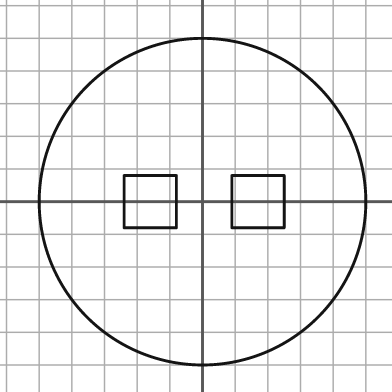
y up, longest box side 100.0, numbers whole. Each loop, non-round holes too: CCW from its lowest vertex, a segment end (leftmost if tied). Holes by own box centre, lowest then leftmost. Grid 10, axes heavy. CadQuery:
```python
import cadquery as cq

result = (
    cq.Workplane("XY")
    .moveTo(0.0, 0.0)
    .circle(50.0)
    .moveTo(-24.0, -8.0)
    .lineTo(-8.0, -8.0)
    .lineTo(-8.0, 8.0)
    .lineTo(-24.0, 8.0)
    .close()
    .moveTo(9.0, -8.0)
    .lineTo(25.0, -8.0)
    .lineTo(25.0, 8.0)
    .lineTo(9.0, 8.0)
    .close()
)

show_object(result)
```